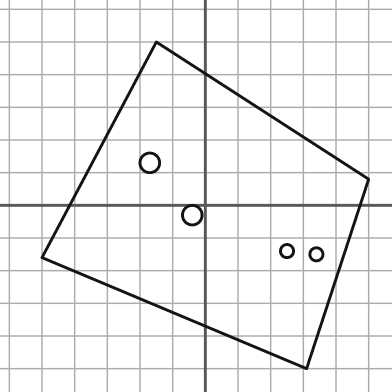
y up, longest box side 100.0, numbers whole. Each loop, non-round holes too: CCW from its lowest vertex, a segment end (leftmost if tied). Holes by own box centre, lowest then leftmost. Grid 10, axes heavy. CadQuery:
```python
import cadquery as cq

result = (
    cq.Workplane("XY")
    .moveTo(31.0, -50.0)
    .lineTo(50.0, 8.0)
    .lineTo(-15.0, 50.0)
    .lineTo(-50.0, -16.0)
    .close()
    .moveTo(34.0, -15.0)
    .circle(2.0)
    .moveTo(25.0, -14.0)
    .circle(2.0)
    .moveTo(-4.0, -3.0)
    .circle(3.0)
    .moveTo(-17.0, 13.0)
    .circle(3.0)
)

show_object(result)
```